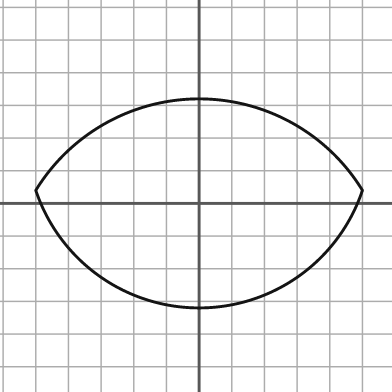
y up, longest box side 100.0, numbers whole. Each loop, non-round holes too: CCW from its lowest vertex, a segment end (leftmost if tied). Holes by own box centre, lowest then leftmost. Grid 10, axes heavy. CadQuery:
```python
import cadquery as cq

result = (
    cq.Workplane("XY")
    .moveTo(-50.0, 4.0)
    .threePointArc((0.0, -32.0), (50.0, 4.0))
    .threePointArc((0.0, 32.0), (-50.0, 4.0))
    .close()
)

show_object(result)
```